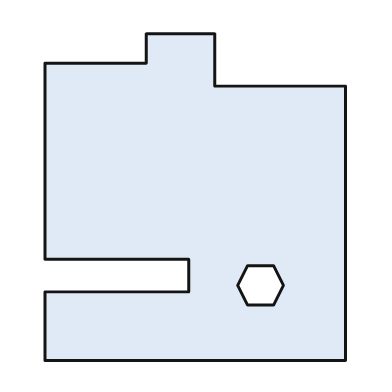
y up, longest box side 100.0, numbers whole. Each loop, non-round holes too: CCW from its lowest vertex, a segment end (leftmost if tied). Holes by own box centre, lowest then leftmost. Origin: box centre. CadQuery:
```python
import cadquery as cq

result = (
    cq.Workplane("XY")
    .moveTo(-46.0, -50.0)
    .lineTo(46.0, -50.0)
    .lineTo(46.0, 34.0)
    .lineTo(6.0, 34.0)
    .lineTo(6.0, 50.0)
    .lineTo(-15.0, 50.0)
    .lineTo(-15.0, 41.0)
    .lineTo(-46.0, 41.0)
    .lineTo(-46.0, -19.0)
    .lineTo(-2.0, -19.0)
    .lineTo(-2.0, -29.0)
    .lineTo(-46.0, -29.0)
    .close()
    .moveTo(16.0, -33.0)
    .lineTo(24.0, -33.0)
    .lineTo(27.0, -27.0)
    .lineTo(24.0, -21.0)
    .lineTo(16.0, -21.0)
    .lineTo(13.0, -27.0)
    .close()
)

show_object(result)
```